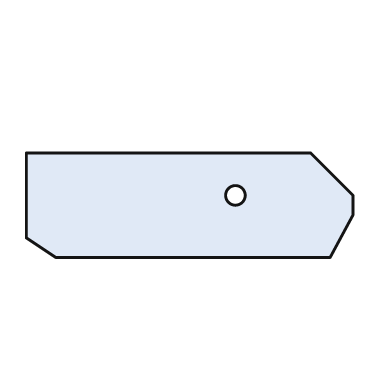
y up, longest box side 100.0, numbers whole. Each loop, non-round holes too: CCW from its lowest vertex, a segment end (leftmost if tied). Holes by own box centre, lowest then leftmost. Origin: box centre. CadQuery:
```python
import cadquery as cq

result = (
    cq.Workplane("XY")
    .moveTo(-41.0, -16.0)
    .lineTo(43.0, -16.0)
    .lineTo(50.0, -3.0)
    .lineTo(50.0, 3.0)
    .lineTo(37.0, 16.0)
    .lineTo(-50.0, 16.0)
    .lineTo(-50.0, -10.0)
    .close()
    .moveTo(14.0, 3.0)
    .circle(3.0)
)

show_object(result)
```